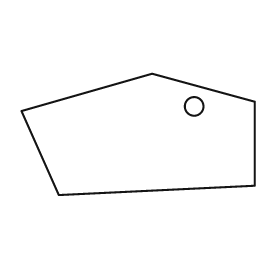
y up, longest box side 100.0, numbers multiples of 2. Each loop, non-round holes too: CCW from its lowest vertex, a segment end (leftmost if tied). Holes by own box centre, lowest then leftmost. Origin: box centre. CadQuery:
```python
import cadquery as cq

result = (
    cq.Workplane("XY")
    .moveTo(-34.0, -26.0)
    .lineTo(50.0, -22.0)
    .lineTo(50.0, 14.0)
    .lineTo(6.0, 26.0)
    .lineTo(-50.0, 10.0)
    .close()
    .moveTo(24.0, 12.0)
    .circle(4.0)
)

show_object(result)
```